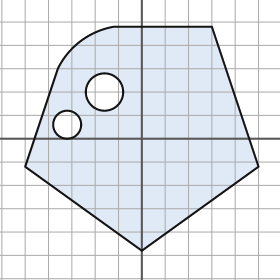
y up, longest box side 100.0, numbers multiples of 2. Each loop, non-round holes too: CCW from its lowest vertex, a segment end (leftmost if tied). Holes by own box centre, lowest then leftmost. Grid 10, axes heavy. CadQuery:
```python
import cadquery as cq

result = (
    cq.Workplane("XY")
    .moveTo(0.0, -48.0)
    .lineTo(50.0, -12.0)
    .lineTo(30.0, 48.0)
    .lineTo(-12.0, 48.0)
    .threePointArc((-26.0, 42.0), (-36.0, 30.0))
    .lineTo(-50.0, -12.0)
    .close()
    .moveTo(-32.0, 6.0)
    .circle(6.0)
    .moveTo(-16.0, 20.0)
    .circle(8.0)
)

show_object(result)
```